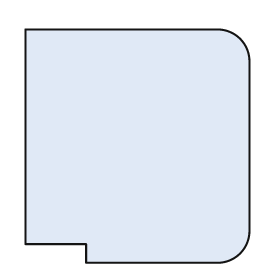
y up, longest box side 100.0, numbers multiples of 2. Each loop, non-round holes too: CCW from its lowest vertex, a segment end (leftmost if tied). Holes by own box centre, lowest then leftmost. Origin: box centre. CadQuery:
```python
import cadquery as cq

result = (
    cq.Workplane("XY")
    .moveTo(-22.0, -50.0)
    .lineTo(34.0, -50.0)
    .threePointArc((44.0, -46.0), (48.0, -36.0))
    .lineTo(48.0, 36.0)
    .threePointArc((44.0, 46.0), (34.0, 50.0))
    .lineTo(-48.0, 50.0)
    .lineTo(-48.0, -42.0)
    .lineTo(-22.0, -42.0)
    .close()
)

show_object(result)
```